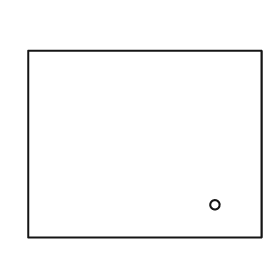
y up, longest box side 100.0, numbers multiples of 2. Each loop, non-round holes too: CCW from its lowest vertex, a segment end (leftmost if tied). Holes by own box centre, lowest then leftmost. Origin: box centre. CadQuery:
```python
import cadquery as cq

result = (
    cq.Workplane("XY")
    .moveTo(-50.0, -40.0)
    .lineTo(50.0, -40.0)
    .lineTo(50.0, 40.0)
    .lineTo(-50.0, 40.0)
    .close()
    .moveTo(30.0, -26.0)
    .circle(2.0)
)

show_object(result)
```